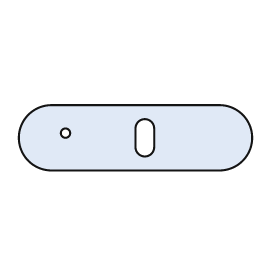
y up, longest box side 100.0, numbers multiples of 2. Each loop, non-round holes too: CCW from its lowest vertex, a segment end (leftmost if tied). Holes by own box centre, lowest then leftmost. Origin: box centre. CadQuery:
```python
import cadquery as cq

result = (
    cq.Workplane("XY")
    .moveTo(-36.0, -14.0)
    .lineTo(36.0, -14.0)
    .threePointArc((50.0, 0.0), (36.0, 14.0))
    .lineTo(-36.0, 14.0)
    .threePointArc((-50.0, 0.0), (-36.0, -14.0))
    .close()
    .moveTo(0.0, -4.0)
    .threePointArc((4.0, -8.0), (8.0, -4.0))
    .lineTo(8.0, 4.0)
    .threePointArc((4.0, 8.0), (0.0, 4.0))
    .close()
    .moveTo(-30.0, 2.0)
    .circle(2.0)
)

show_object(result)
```